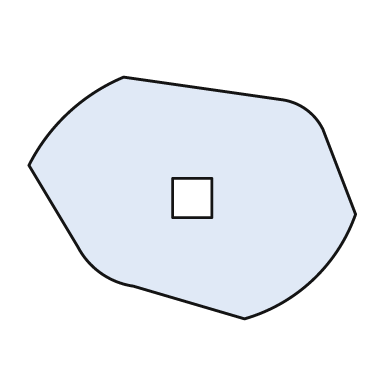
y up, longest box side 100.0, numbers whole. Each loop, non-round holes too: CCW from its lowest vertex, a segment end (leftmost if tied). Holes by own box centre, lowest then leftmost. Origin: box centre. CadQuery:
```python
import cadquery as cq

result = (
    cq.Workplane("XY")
    .moveTo(16.0, -37.0)
    .threePointArc((37.0, -25.0), (50.0, -5.0))
    .lineTo(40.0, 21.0)
    .threePointArc((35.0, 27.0), (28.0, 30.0))
    .lineTo(-21.0, 37.0)
    .threePointArc((-38.0, 26.0), (-50.0, 10.0))
    .lineTo(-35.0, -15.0)
    .threePointArc((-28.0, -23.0), (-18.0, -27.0))
    .close()
    .moveTo(-6.0, -6.0)
    .lineTo(6.0, -6.0)
    .lineTo(6.0, 6.0)
    .lineTo(-6.0, 6.0)
    .close()
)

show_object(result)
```